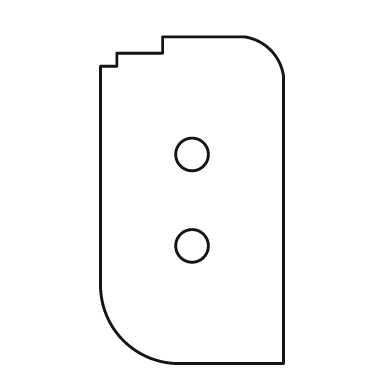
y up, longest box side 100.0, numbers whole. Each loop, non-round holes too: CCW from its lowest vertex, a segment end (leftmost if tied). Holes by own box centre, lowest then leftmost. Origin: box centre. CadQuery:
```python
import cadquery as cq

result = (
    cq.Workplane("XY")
    .moveTo(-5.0, -50.0)
    .lineTo(28.0, -50.0)
    .lineTo(28.0, 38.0)
    .threePointArc((24.0, 46.0), (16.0, 50.0))
    .lineTo(-9.0, 50.0)
    .lineTo(-9.0, 45.0)
    .lineTo(-23.0, 45.0)
    .lineTo(-23.0, 41.0)
    .lineTo(-28.0, 41.0)
    .lineTo(-28.0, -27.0)
    .threePointArc((-21.0, -43.0), (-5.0, -50.0))
    .close()
    .moveTo(0.0, -14.0)
    .circle(5.0)
    .moveTo(0.0, 14.0)
    .circle(5.0)
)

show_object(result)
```